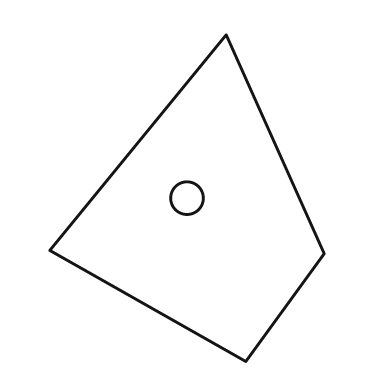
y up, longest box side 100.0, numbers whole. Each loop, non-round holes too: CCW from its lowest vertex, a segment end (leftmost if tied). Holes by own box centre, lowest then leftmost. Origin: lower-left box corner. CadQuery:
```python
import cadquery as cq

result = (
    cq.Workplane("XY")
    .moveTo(60.0, 0.0)
    .lineTo(84.0, 33.0)
    .lineTo(54.0, 100.0)
    .lineTo(0.0, 34.0)
    .close()
    .moveTo(42.0, 50.0)
    .circle(5.0)
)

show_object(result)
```